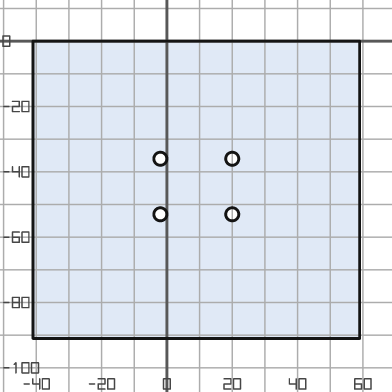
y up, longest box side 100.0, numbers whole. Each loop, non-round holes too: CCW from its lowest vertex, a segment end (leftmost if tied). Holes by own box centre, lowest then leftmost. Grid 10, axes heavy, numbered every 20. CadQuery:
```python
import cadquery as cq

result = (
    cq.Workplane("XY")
    .moveTo(-41.0, -91.0)
    .lineTo(59.0, -91.0)
    .lineTo(59.0, 0.0)
    .lineTo(-41.0, 0.0)
    .close()
    .moveTo(-2.0, -53.0)
    .circle(2.0)
    .moveTo(20.0, -53.0)
    .circle(2.0)
    .moveTo(-2.0, -36.0)
    .circle(2.0)
    .moveTo(20.0, -36.0)
    .circle(2.0)
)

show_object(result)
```